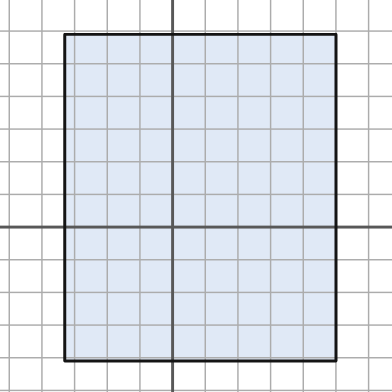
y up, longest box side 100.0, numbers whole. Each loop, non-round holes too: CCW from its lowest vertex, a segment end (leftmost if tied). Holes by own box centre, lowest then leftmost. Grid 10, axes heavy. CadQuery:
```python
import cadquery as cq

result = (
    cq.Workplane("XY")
    .moveTo(-33.0, -41.0)
    .lineTo(50.0, -41.0)
    .lineTo(50.0, 59.0)
    .lineTo(-33.0, 59.0)
    .close()
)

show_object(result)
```